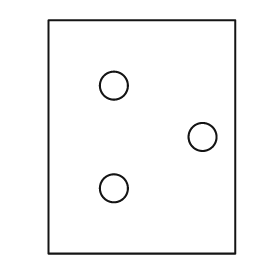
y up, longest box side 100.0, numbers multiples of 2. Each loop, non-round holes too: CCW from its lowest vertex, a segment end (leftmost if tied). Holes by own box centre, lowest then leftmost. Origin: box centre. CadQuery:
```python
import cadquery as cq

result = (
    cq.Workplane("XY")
    .moveTo(-40.0, -50.0)
    .lineTo(40.0, -50.0)
    .lineTo(40.0, 50.0)
    .lineTo(-40.0, 50.0)
    .close()
    .moveTo(-12.0, -22.0)
    .circle(6.0)
    .moveTo(26.0, 0.0)
    .circle(6.0)
    .moveTo(-12.0, 22.0)
    .circle(6.0)
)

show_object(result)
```